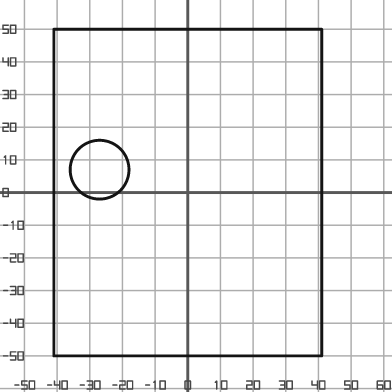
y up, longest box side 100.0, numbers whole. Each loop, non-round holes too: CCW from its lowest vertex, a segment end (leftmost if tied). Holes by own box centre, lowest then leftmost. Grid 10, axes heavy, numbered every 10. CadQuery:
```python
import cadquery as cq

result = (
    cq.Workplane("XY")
    .moveTo(-41.0, -50.0)
    .lineTo(41.0, -50.0)
    .lineTo(41.0, 50.0)
    .lineTo(-41.0, 50.0)
    .close()
    .moveTo(-27.0, 7.0)
    .circle(9.0)
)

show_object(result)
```